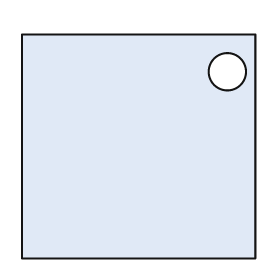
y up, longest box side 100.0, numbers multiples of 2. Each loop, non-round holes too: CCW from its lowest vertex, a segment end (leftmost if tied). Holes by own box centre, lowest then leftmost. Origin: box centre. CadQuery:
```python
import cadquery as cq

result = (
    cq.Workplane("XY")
    .moveTo(-50.0, -48.0)
    .lineTo(50.0, -48.0)
    .lineTo(50.0, 48.0)
    .lineTo(-50.0, 48.0)
    .close()
    .moveTo(38.0, 32.0)
    .circle(8.0)
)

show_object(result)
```